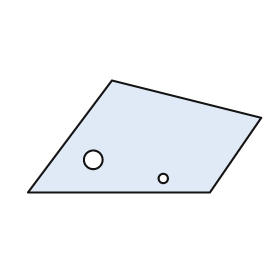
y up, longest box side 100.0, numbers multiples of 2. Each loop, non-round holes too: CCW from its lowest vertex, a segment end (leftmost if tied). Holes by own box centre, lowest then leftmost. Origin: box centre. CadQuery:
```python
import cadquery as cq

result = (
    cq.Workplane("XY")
    .moveTo(-50.0, -24.0)
    .lineTo(28.0, -24.0)
    .lineTo(50.0, 8.0)
    .lineTo(-14.0, 24.0)
    .close()
    .moveTo(8.0, -18.0)
    .circle(2.0)
    .moveTo(-22.0, -10.0)
    .circle(4.0)
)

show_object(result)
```